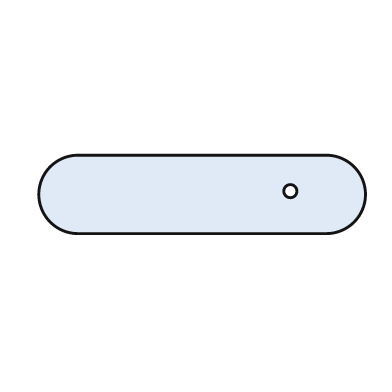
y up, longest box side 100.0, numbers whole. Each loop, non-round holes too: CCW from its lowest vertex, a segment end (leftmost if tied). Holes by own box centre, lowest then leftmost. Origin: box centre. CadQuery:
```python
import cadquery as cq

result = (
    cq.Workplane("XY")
    .moveTo(-38.0, -12.0)
    .lineTo(38.0, -12.0)
    .threePointArc((50.0, 0.0), (38.0, 12.0))
    .lineTo(-38.0, 12.0)
    .threePointArc((-50.0, 0.0), (-38.0, -12.0))
    .close()
    .moveTo(27.0, 1.0)
    .circle(2.0)
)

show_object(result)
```